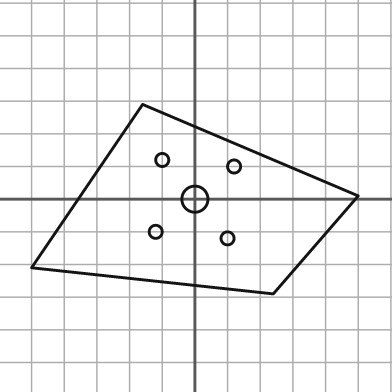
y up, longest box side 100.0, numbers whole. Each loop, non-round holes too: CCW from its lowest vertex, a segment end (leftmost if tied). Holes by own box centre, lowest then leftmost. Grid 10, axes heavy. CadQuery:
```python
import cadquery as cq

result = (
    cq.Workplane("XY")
    .moveTo(24.0, -29.0)
    .lineTo(50.0, 1.0)
    .lineTo(-16.0, 29.0)
    .lineTo(-50.0, -21.0)
    .close()
    .moveTo(10.0, -12.0)
    .circle(2.0)
    .moveTo(-12.0, -10.0)
    .circle(2.0)
    .moveTo(0.0, 0.0)
    .circle(4.0)
    .moveTo(12.0, 10.0)
    .circle(2.0)
    .moveTo(-10.0, 12.0)
    .circle(2.0)
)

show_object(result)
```